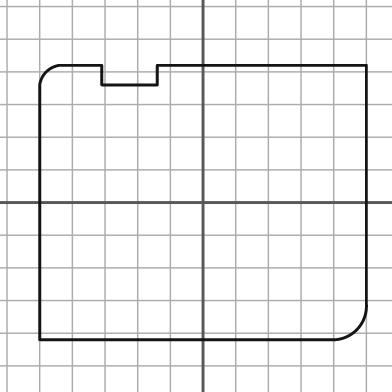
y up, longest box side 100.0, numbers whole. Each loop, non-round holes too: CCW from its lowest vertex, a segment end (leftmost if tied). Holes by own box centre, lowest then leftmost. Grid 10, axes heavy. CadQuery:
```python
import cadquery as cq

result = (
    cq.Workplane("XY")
    .moveTo(-50.0, -42.0)
    .lineTo(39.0, -42.0)
    .threePointArc((47.0, -39.0), (50.0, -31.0))
    .lineTo(50.0, 42.0)
    .lineTo(-14.0, 42.0)
    .lineTo(-14.0, 36.0)
    .lineTo(-31.0, 36.0)
    .lineTo(-31.0, 42.0)
    .lineTo(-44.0, 42.0)
    .threePointArc((-48.0, 40.0), (-50.0, 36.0))
    .close()
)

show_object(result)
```